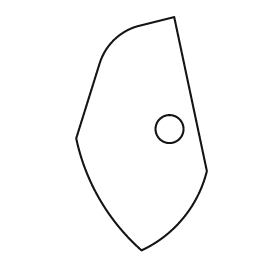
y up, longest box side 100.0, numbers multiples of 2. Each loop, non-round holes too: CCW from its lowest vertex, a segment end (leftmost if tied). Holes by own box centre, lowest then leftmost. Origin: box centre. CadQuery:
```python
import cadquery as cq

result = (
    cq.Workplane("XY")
    .moveTo(0.0, -50.0)
    .threePointArc((18.0, -36.0), (28.0, -16.0))
    .lineTo(14.0, 50.0)
    .lineTo(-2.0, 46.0)
    .threePointArc((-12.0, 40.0), (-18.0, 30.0))
    .lineTo(-28.0, -2.0)
    .threePointArc((-18.0, -28.0), (0.0, -50.0))
    .close()
    .moveTo(12.0, 2.0)
    .circle(6.0)
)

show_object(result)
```